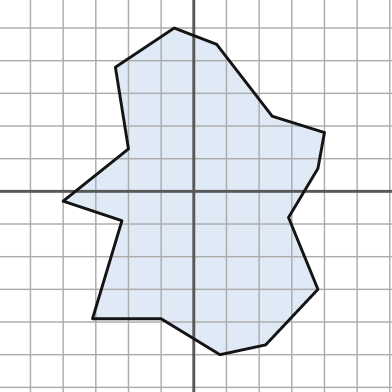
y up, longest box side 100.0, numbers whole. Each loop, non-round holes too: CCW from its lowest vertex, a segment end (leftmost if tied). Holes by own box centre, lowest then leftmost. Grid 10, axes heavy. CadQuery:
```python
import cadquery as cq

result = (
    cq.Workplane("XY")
    .moveTo(8.0, -50.0)
    .lineTo(22.0, -47.0)
    .lineTo(38.0, -30.0)
    .lineTo(29.0, -8.0)
    .lineTo(38.0, 7.0)
    .lineTo(40.0, 18.0)
    .lineTo(24.0, 23.0)
    .lineTo(7.0, 45.0)
    .lineTo(-6.0, 50.0)
    .lineTo(-24.0, 38.0)
    .lineTo(-20.0, 13.0)
    .lineTo(-40.0, -3.0)
    .lineTo(-22.0, -9.0)
    .lineTo(-31.0, -39.0)
    .lineTo(-10.0, -39.0)
    .close()
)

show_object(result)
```